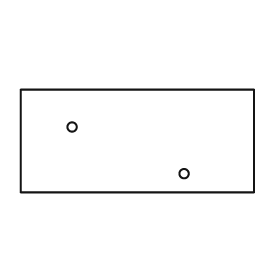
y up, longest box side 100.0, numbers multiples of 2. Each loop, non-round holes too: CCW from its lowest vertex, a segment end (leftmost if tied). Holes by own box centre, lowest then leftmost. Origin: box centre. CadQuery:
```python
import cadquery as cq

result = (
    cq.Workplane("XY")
    .moveTo(-50.0, -22.0)
    .lineTo(50.0, -22.0)
    .lineTo(50.0, 22.0)
    .lineTo(-50.0, 22.0)
    .close()
    .moveTo(20.0, -14.0)
    .circle(2.0)
    .moveTo(-28.0, 6.0)
    .circle(2.0)
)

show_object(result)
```